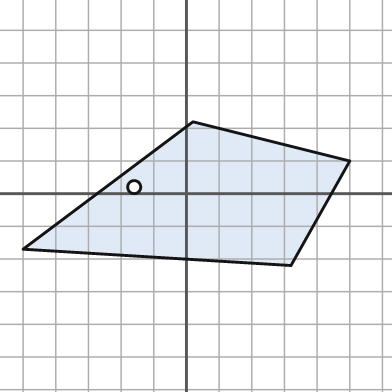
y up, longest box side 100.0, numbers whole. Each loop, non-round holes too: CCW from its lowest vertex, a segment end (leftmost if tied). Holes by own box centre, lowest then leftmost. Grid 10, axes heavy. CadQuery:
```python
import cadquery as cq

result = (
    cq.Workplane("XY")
    .moveTo(32.0, -22.0)
    .lineTo(50.0, 10.0)
    .lineTo(2.0, 22.0)
    .lineTo(-50.0, -17.0)
    .close()
    .moveTo(-16.0, 2.0)
    .circle(2.0)
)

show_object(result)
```